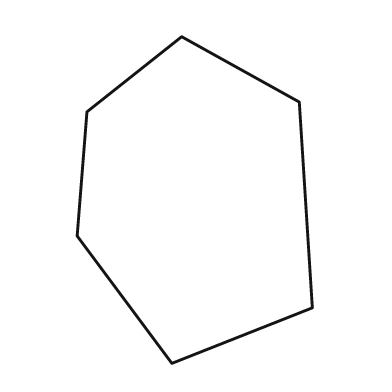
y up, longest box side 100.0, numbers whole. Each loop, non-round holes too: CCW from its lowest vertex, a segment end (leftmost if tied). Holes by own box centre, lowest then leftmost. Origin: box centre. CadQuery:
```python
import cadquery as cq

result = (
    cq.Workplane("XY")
    .moveTo(-7.0, -50.0)
    .lineTo(36.0, -33.0)
    .lineTo(32.0, 30.0)
    .lineTo(-4.0, 50.0)
    .lineTo(-33.0, 27.0)
    .lineTo(-36.0, -11.0)
    .close()
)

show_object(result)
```